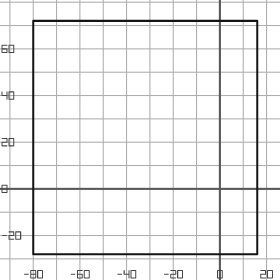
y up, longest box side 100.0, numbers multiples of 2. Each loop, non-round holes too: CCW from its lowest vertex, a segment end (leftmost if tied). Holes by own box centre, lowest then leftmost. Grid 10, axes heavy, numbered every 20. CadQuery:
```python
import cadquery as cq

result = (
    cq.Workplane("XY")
    .moveTo(-80.0, -28.0)
    .lineTo(16.0, -28.0)
    .lineTo(16.0, 72.0)
    .lineTo(-80.0, 72.0)
    .close()
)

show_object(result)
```